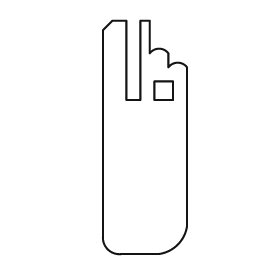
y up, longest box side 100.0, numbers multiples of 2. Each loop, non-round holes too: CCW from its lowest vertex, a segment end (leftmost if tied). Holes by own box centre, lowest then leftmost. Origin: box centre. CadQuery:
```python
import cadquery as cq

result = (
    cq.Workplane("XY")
    .moveTo(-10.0, -50.0)
    .lineTo(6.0, -50.0)
    .threePointArc((14.0, -46.0), (18.0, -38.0))
    .lineTo(18.0, 30.0)
    .threePointArc((14.0, 32.0), (10.0, 30.0))
    .lineTo(10.0, 36.0)
    .threePointArc((6.0, 38.0), (2.0, 36.0))
    .lineTo(2.0, 50.0)
    .lineTo(-2.0, 50.0)
    .lineTo(-2.0, 16.0)
    .lineTo(-8.0, 16.0)
    .lineTo(-8.0, 50.0)
    .lineTo(-14.0, 50.0)
    .lineTo(-18.0, 46.0)
    .lineTo(-18.0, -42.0)
    .threePointArc((-16.0, -48.0), (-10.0, -50.0))
    .close()
    .moveTo(4.0, 16.0)
    .lineTo(12.0, 16.0)
    .lineTo(12.0, 24.0)
    .lineTo(4.0, 24.0)
    .close()
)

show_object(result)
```